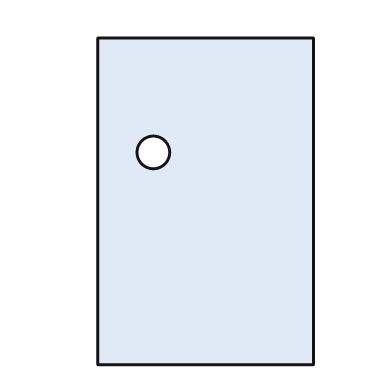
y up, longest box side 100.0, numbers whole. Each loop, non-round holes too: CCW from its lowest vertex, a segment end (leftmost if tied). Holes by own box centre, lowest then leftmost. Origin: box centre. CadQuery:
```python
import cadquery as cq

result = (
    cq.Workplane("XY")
    .moveTo(-33.0, -50.0)
    .lineTo(33.0, -50.0)
    .lineTo(33.0, 50.0)
    .lineTo(-33.0, 50.0)
    .close()
    .moveTo(-16.0, 15.0)
    .circle(5.0)
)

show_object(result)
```